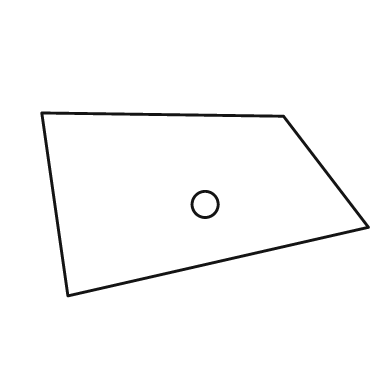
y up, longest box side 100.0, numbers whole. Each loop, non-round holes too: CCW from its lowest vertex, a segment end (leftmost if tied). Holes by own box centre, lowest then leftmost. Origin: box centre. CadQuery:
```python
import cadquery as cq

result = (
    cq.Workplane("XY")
    .moveTo(-42.0, -28.0)
    .lineTo(50.0, -7.0)
    .lineTo(24.0, 27.0)
    .lineTo(-50.0, 28.0)
    .close()
    .moveTo(0.0, 0.0)
    .circle(4.0)
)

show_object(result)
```